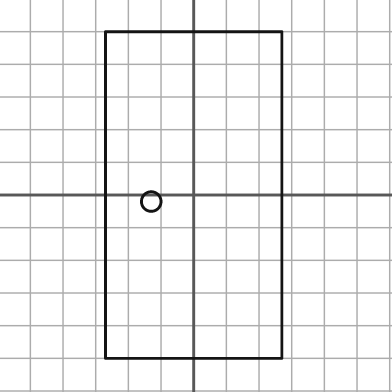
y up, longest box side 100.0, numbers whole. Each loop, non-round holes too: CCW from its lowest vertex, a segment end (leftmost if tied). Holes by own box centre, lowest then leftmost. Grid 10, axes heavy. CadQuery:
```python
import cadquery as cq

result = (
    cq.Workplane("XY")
    .moveTo(-27.0, -50.0)
    .lineTo(27.0, -50.0)
    .lineTo(27.0, 50.0)
    .lineTo(-27.0, 50.0)
    .close()
    .moveTo(-13.0, -2.0)
    .circle(3.0)
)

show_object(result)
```